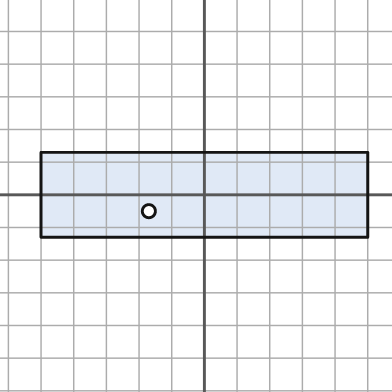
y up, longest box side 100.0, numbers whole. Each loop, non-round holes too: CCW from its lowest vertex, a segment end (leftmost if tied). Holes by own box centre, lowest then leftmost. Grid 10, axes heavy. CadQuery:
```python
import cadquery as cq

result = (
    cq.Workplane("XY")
    .moveTo(-50.0, -13.0)
    .lineTo(50.0, -13.0)
    .lineTo(50.0, 13.0)
    .lineTo(-50.0, 13.0)
    .close()
    .moveTo(-17.0, -5.0)
    .circle(2.0)
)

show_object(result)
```